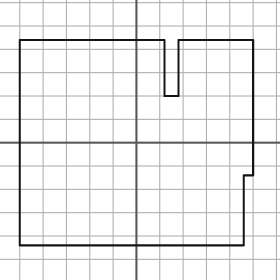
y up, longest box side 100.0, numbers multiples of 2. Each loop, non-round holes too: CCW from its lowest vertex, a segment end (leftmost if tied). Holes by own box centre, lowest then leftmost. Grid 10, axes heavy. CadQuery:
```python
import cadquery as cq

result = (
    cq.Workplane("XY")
    .moveTo(-50.0, -44.0)
    .lineTo(46.0, -44.0)
    .lineTo(46.0, -14.0)
    .lineTo(50.0, -14.0)
    .lineTo(50.0, 44.0)
    .lineTo(18.0, 44.0)
    .lineTo(18.0, 20.0)
    .lineTo(12.0, 20.0)
    .lineTo(12.0, 44.0)
    .lineTo(-50.0, 44.0)
    .close()
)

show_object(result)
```